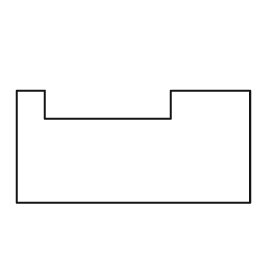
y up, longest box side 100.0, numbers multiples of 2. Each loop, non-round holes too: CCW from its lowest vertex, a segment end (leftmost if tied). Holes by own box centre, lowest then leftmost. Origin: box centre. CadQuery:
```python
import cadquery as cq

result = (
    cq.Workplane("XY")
    .moveTo(-50.0, -24.0)
    .lineTo(50.0, -24.0)
    .lineTo(50.0, 24.0)
    .lineTo(16.0, 24.0)
    .lineTo(16.0, 12.0)
    .lineTo(-38.0, 12.0)
    .lineTo(-38.0, 24.0)
    .lineTo(-50.0, 24.0)
    .close()
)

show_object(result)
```